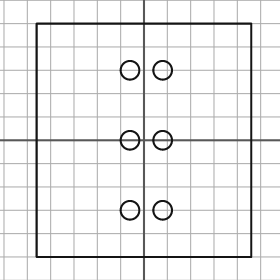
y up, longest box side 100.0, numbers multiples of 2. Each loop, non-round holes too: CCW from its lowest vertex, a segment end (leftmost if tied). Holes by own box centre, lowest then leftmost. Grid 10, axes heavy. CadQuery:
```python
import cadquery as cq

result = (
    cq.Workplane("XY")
    .moveTo(-46.0, -50.0)
    .lineTo(46.0, -50.0)
    .lineTo(46.0, 50.0)
    .lineTo(-46.0, 50.0)
    .close()
    .moveTo(-6.0, -30.0)
    .circle(4.0)
    .moveTo(8.0, -30.0)
    .circle(4.0)
    .moveTo(-6.0, 0.0)
    .circle(4.0)
    .moveTo(8.0, 0.0)
    .circle(4.0)
    .moveTo(-6.0, 30.0)
    .circle(4.0)
    .moveTo(8.0, 30.0)
    .circle(4.0)
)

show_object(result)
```